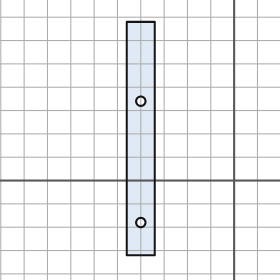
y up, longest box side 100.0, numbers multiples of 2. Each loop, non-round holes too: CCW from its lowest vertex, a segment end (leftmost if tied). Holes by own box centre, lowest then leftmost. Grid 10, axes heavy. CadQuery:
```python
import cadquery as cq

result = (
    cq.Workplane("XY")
    .moveTo(-46.0, -32.0)
    .lineTo(-34.0, -32.0)
    .lineTo(-34.0, 68.0)
    .lineTo(-46.0, 68.0)
    .close()
    .moveTo(-40.0, -18.0)
    .circle(2.0)
    .moveTo(-40.0, 34.0)
    .circle(2.0)
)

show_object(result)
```